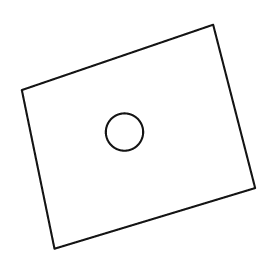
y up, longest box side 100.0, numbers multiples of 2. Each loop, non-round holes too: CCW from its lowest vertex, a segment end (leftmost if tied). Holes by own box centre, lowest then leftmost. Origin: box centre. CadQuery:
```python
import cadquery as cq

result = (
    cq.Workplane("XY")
    .moveTo(-36.0, -48.0)
    .lineTo(50.0, -22.0)
    .lineTo(32.0, 48.0)
    .lineTo(-50.0, 20.0)
    .close()
    .moveTo(-6.0, 2.0)
    .circle(8.0)
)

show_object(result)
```